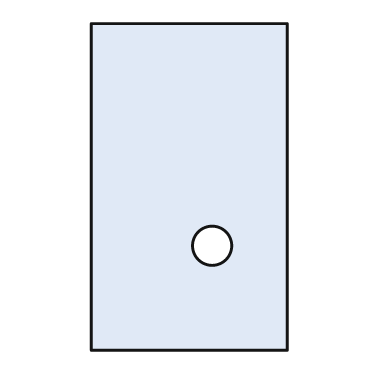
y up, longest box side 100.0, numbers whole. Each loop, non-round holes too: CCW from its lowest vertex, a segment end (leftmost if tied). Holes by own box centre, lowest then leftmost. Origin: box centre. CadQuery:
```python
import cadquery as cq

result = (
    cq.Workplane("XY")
    .moveTo(-30.0, -50.0)
    .lineTo(30.0, -50.0)
    .lineTo(30.0, 50.0)
    .lineTo(-30.0, 50.0)
    .close()
    .moveTo(7.0, -18.0)
    .circle(6.0)
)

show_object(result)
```